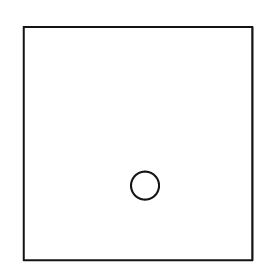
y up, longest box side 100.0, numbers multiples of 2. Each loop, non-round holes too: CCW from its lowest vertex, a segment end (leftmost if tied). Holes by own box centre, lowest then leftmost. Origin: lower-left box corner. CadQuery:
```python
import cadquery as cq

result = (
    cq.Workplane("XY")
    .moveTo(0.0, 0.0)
    .lineTo(98.0, 0.0)
    .lineTo(98.0, 100.0)
    .lineTo(0.0, 100.0)
    .close()
    .moveTo(52.0, 32.0)
    .circle(6.0)
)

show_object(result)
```